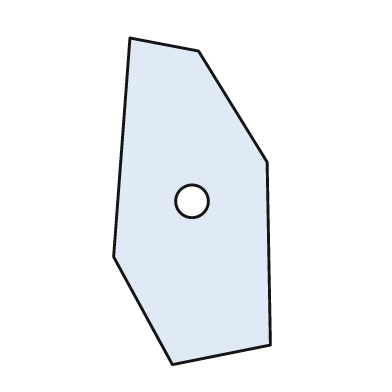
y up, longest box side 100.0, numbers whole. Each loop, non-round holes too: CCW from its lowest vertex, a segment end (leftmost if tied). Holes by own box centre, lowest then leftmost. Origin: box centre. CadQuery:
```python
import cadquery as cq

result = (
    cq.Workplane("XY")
    .moveTo(-6.0, -50.0)
    .lineTo(24.0, -44.0)
    .lineTo(23.0, 12.0)
    .lineTo(2.0, 46.0)
    .lineTo(-19.0, 50.0)
    .lineTo(-24.0, -17.0)
    .close()
    .moveTo(0.0, 0.0)
    .circle(5.0)
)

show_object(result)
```